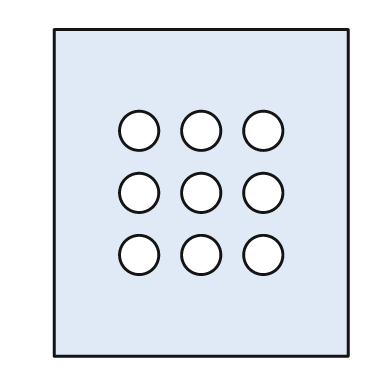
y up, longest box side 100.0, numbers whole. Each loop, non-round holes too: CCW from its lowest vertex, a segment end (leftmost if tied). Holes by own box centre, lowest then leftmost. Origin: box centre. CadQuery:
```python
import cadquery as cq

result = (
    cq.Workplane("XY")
    .moveTo(-45.0, -50.0)
    .lineTo(45.0, -50.0)
    .lineTo(45.0, 50.0)
    .lineTo(-45.0, 50.0)
    .close()
    .moveTo(-19.0, -19.0)
    .circle(6.0)
    .moveTo(0.0, -19.0)
    .circle(6.0)
    .moveTo(19.0, -19.0)
    .circle(6.0)
    .moveTo(-19.0, 0.0)
    .circle(6.0)
    .moveTo(0.0, 0.0)
    .circle(6.0)
    .moveTo(19.0, 0.0)
    .circle(6.0)
    .moveTo(-19.0, 19.0)
    .circle(6.0)
    .moveTo(0.0, 19.0)
    .circle(6.0)
    .moveTo(19.0, 19.0)
    .circle(6.0)
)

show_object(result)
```